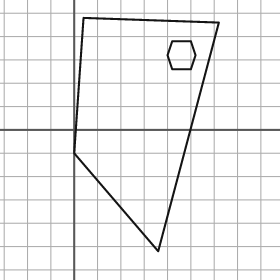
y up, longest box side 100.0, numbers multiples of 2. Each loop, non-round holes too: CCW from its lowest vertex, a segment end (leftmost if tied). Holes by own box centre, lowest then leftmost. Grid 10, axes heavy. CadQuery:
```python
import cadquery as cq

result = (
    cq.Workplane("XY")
    .moveTo(36.0, -52.0)
    .lineTo(62.0, 46.0)
    .lineTo(4.0, 48.0)
    .lineTo(0.0, -10.0)
    .close()
    .moveTo(42.0, 26.0)
    .lineTo(50.0, 26.0)
    .lineTo(52.0, 32.0)
    .lineTo(50.0, 38.0)
    .lineTo(42.0, 38.0)
    .lineTo(40.0, 32.0)
    .close()
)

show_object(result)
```